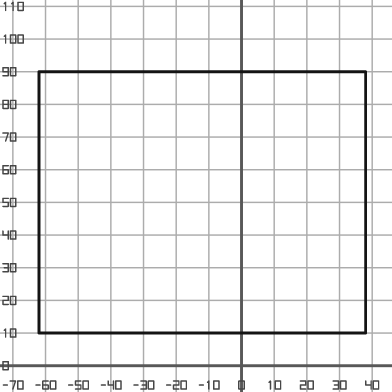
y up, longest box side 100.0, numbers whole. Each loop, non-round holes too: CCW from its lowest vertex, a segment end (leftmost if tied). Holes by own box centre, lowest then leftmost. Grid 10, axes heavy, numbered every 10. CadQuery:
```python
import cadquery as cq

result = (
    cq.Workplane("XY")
    .moveTo(-62.0, 10.0)
    .lineTo(38.0, 10.0)
    .lineTo(38.0, 90.0)
    .lineTo(-62.0, 90.0)
    .close()
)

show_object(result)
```